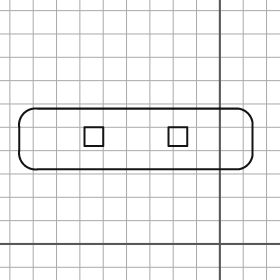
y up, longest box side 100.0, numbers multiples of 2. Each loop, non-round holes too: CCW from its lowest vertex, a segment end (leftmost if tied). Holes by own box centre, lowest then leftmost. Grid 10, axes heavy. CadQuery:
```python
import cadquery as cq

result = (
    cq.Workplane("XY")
    .moveTo(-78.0, 32.0)
    .lineTo(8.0, 32.0)
    .threePointArc((12.0, 34.0), (14.0, 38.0))
    .lineTo(14.0, 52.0)
    .threePointArc((12.0, 56.0), (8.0, 58.0))
    .lineTo(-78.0, 58.0)
    .threePointArc((-84.0, 56.0), (-86.0, 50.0))
    .lineTo(-86.0, 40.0)
    .threePointArc((-84.0, 34.0), (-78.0, 32.0))
    .close()
    .moveTo(-58.0, 42.0)
    .lineTo(-50.0, 42.0)
    .lineTo(-50.0, 50.0)
    .lineTo(-58.0, 50.0)
    .close()
    .moveTo(-22.0, 42.0)
    .lineTo(-14.0, 42.0)
    .lineTo(-14.0, 50.0)
    .lineTo(-22.0, 50.0)
    .close()
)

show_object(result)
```